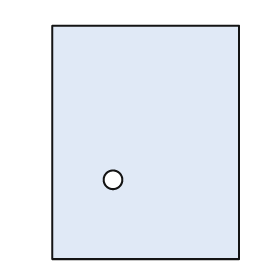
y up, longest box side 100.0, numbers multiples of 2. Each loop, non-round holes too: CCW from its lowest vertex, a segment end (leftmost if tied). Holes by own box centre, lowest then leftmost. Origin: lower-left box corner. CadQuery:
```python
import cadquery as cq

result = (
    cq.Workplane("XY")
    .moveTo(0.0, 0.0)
    .lineTo(80.0, 0.0)
    .lineTo(80.0, 100.0)
    .lineTo(0.0, 100.0)
    .close()
    .moveTo(26.0, 34.0)
    .circle(4.0)
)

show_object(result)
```